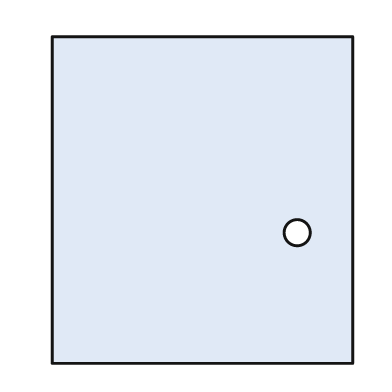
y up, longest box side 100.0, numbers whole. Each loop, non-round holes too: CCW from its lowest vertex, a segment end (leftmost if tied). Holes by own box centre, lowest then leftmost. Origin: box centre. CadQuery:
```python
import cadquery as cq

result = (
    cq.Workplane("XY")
    .moveTo(-46.0, -50.0)
    .lineTo(46.0, -50.0)
    .lineTo(46.0, 50.0)
    .lineTo(-46.0, 50.0)
    .close()
    .moveTo(29.0, -10.0)
    .circle(4.0)
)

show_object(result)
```